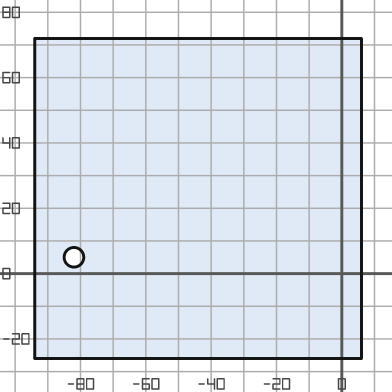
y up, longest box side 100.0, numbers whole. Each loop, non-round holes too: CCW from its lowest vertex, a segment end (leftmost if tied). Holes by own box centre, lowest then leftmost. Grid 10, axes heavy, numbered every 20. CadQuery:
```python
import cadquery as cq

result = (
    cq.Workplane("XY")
    .moveTo(-94.0, -26.0)
    .lineTo(6.0, -26.0)
    .lineTo(6.0, 72.0)
    .lineTo(-94.0, 72.0)
    .close()
    .moveTo(-82.0, 5.0)
    .circle(3.0)
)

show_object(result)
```